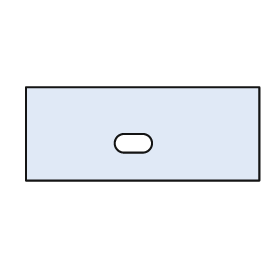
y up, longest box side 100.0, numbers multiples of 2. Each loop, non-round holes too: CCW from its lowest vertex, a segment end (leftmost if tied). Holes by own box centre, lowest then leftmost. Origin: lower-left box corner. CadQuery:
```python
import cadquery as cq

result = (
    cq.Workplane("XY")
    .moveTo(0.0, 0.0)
    .lineTo(100.0, 0.0)
    .lineTo(100.0, 40.0)
    .lineTo(0.0, 40.0)
    .close()
    .moveTo(42.0, 12.0)
    .lineTo(50.0, 12.0)
    .threePointArc((54.0, 16.0), (50.0, 20.0))
    .lineTo(42.0, 20.0)
    .threePointArc((38.0, 16.0), (42.0, 12.0))
    .close()
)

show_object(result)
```